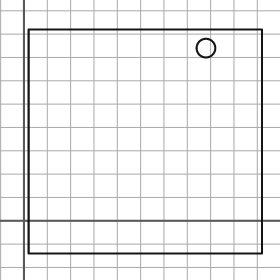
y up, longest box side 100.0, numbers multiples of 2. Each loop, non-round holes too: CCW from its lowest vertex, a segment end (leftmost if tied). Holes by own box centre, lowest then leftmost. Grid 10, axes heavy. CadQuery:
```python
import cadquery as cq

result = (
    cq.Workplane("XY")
    .moveTo(2.0, -14.0)
    .lineTo(102.0, -14.0)
    .lineTo(102.0, 82.0)
    .lineTo(2.0, 82.0)
    .close()
    .moveTo(78.0, 74.0)
    .circle(4.0)
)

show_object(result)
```